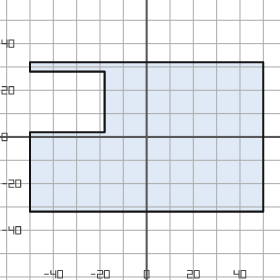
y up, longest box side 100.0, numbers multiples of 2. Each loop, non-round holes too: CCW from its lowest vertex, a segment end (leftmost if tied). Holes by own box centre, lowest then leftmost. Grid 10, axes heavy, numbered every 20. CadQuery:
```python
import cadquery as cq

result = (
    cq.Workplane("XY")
    .moveTo(-50.0, -32.0)
    .lineTo(50.0, -32.0)
    .lineTo(50.0, 32.0)
    .lineTo(-50.0, 32.0)
    .lineTo(-50.0, 28.0)
    .lineTo(-18.0, 28.0)
    .lineTo(-18.0, 2.0)
    .lineTo(-50.0, 2.0)
    .close()
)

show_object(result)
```